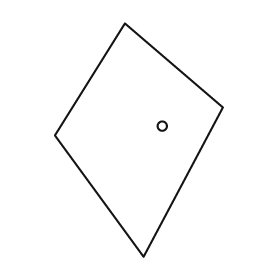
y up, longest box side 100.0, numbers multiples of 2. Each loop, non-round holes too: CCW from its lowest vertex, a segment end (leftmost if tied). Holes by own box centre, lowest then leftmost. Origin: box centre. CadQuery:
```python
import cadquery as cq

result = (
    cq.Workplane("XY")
    .moveTo(2.0, -50.0)
    .lineTo(36.0, 14.0)
    .lineTo(-6.0, 50.0)
    .lineTo(-36.0, 2.0)
    .close()
    .moveTo(10.0, 6.0)
    .circle(2.0)
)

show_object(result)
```